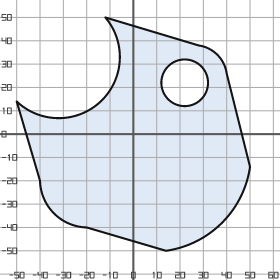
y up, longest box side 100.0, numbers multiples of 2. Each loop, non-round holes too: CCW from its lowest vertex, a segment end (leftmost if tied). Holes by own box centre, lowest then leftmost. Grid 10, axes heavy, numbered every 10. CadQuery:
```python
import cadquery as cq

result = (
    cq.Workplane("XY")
    .moveTo(14.0, -50.0)
    .threePointArc((38.0, -38.0), (50.0, -14.0))
    .lineTo(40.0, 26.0)
    .threePointArc((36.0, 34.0), (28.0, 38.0))
    .lineTo(-12.0, 50.0)
    .threePointArc((-14.0, 14.0), (-50.0, 14.0))
    .lineTo(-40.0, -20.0)
    .threePointArc((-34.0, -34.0), (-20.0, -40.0))
    .close()
    .moveTo(22.0, 22.0)
    .circle(10.0)
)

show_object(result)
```